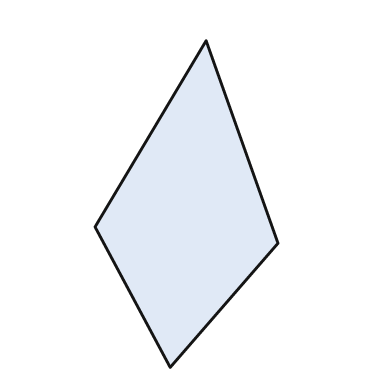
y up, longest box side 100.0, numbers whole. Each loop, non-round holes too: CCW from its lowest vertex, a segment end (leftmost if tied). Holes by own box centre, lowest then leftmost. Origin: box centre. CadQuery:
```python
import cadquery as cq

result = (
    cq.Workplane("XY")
    .moveTo(-5.0, -50.0)
    .lineTo(28.0, -12.0)
    .lineTo(6.0, 50.0)
    .lineTo(-28.0, -7.0)
    .close()
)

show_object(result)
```